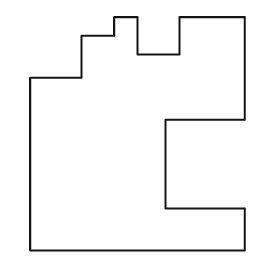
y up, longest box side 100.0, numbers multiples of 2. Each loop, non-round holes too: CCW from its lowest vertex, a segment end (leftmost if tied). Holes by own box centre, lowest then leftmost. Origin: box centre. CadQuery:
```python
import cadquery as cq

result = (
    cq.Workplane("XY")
    .moveTo(-46.0, -50.0)
    .lineTo(46.0, -50.0)
    .lineTo(46.0, -32.0)
    .lineTo(12.0, -32.0)
    .lineTo(12.0, 6.0)
    .lineTo(46.0, 6.0)
    .lineTo(46.0, 50.0)
    .lineTo(18.0, 50.0)
    .lineTo(18.0, 34.0)
    .lineTo(0.0, 34.0)
    .lineTo(0.0, 50.0)
    .lineTo(-10.0, 50.0)
    .lineTo(-10.0, 42.0)
    .lineTo(-24.0, 42.0)
    .lineTo(-24.0, 24.0)
    .lineTo(-46.0, 24.0)
    .close()
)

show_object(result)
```